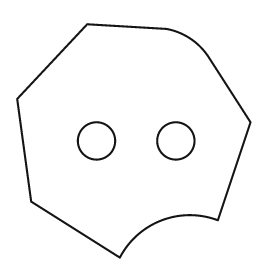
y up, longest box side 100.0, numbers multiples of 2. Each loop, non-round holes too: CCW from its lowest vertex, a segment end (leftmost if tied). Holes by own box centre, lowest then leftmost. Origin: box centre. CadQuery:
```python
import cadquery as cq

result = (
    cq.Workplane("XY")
    .moveTo(-6.0, -50.0)
    .threePointArc((12.0, -34.0), (36.0, -34.0))
    .lineTo(50.0, 8.0)
    .lineTo(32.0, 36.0)
    .threePointArc((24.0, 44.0), (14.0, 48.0))
    .lineTo(-20.0, 50.0)
    .lineTo(-50.0, 18.0)
    .lineTo(-44.0, -26.0)
    .close()
    .moveTo(-16.0, 0.0)
    .circle(8.0)
    .moveTo(18.0, 0.0)
    .circle(8.0)
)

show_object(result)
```